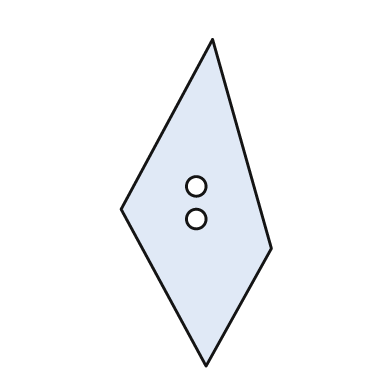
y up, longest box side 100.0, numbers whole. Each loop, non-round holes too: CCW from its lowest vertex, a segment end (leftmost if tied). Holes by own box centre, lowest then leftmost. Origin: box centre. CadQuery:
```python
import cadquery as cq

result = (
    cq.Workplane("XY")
    .moveTo(3.0, -50.0)
    .lineTo(23.0, -14.0)
    .lineTo(5.0, 50.0)
    .lineTo(-23.0, -2.0)
    .close()
    .moveTo(0.0, -5.0)
    .circle(3.0)
    .moveTo(0.0, 5.0)
    .circle(3.0)
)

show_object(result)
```